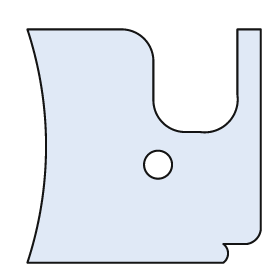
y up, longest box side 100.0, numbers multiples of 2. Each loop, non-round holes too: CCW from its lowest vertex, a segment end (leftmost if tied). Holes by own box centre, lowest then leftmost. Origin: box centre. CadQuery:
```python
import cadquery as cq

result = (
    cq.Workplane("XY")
    .moveTo(-50.0, -50.0)
    .lineTo(34.0, -50.0)
    .threePointArc((36.0, -46.0), (34.0, -42.0))
    .lineTo(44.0, -42.0)
    .threePointArc((48.0, -40.0), (50.0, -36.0))
    .lineTo(50.0, 50.0)
    .lineTo(40.0, 50.0)
    .lineTo(40.0, 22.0)
    .threePointArc((36.0, 10.0), (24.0, 6.0))
    .lineTo(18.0, 6.0)
    .threePointArc((8.0, 10.0), (4.0, 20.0))
    .lineTo(4.0, 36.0)
    .threePointArc((0.0, 46.0), (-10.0, 50.0))
    .lineTo(-50.0, 50.0)
    .threePointArc((-42.0, 0.0), (-50.0, -50.0))
    .close()
    .moveTo(6.0, -8.0)
    .circle(6.0)
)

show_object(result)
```